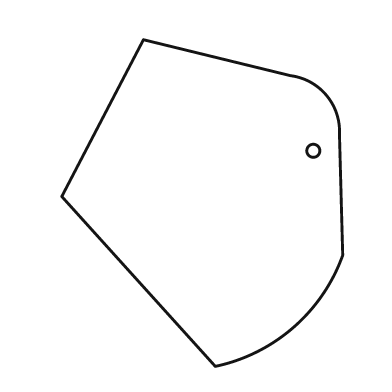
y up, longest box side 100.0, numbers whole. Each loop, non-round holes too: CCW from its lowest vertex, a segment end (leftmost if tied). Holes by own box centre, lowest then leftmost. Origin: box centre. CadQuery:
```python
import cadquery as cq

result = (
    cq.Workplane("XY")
    .moveTo(4.0, -50.0)
    .threePointArc((28.0, -38.0), (43.0, -16.0))
    .lineTo(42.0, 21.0)
    .threePointArc((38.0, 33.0), (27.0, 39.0))
    .lineTo(-18.0, 50.0)
    .lineTo(-43.0, 2.0)
    .close()
    .moveTo(34.0, 16.0)
    .circle(2.0)
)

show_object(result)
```